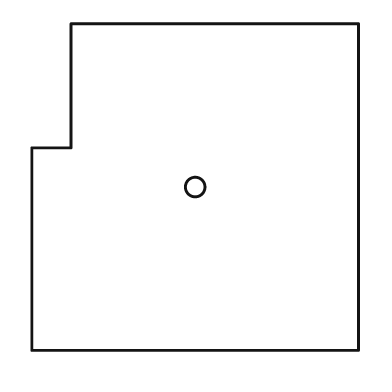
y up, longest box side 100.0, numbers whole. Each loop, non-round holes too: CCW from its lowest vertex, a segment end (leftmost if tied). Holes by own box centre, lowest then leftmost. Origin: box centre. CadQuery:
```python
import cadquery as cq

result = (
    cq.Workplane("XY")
    .moveTo(-50.0, -50.0)
    .lineTo(50.0, -50.0)
    .lineTo(50.0, 50.0)
    .lineTo(-38.0, 50.0)
    .lineTo(-38.0, 12.0)
    .lineTo(-50.0, 12.0)
    .close()
    .moveTo(0.0, 0.0)
    .circle(3.0)
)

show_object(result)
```